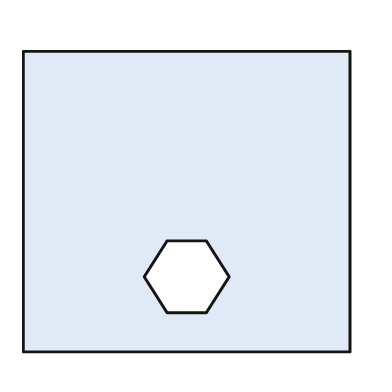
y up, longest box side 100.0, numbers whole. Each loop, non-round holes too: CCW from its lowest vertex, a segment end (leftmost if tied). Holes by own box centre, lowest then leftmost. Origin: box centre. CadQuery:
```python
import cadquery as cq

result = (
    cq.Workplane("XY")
    .moveTo(-50.0, -46.0)
    .lineTo(50.0, -46.0)
    .lineTo(50.0, 46.0)
    .lineTo(-50.0, 46.0)
    .close()
    .moveTo(-6.0, -34.0)
    .lineTo(6.0, -34.0)
    .lineTo(13.0, -23.0)
    .lineTo(6.0, -12.0)
    .lineTo(-6.0, -12.0)
    .lineTo(-13.0, -23.0)
    .close()
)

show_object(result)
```